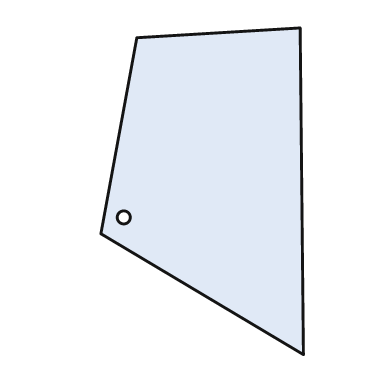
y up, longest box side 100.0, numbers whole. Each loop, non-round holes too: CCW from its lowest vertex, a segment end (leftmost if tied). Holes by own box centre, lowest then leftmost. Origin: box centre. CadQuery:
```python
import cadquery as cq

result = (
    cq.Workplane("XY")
    .moveTo(31.0, -50.0)
    .lineTo(30.0, 50.0)
    .lineTo(-20.0, 47.0)
    .lineTo(-31.0, -13.0)
    .close()
    .moveTo(-24.0, -8.0)
    .circle(2.0)
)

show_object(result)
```